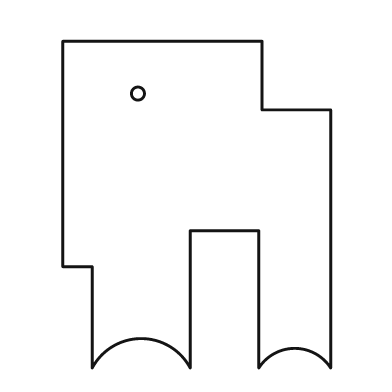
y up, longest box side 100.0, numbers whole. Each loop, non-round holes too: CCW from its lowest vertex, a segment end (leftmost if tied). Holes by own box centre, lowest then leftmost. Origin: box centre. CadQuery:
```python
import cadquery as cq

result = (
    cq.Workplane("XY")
    .moveTo(-32.0, -50.0)
    .threePointArc((-17.0, -41.0), (-2.0, -50.0))
    .lineTo(-2.0, -8.0)
    .lineTo(19.0, -8.0)
    .lineTo(19.0, -50.0)
    .threePointArc((30.0, -44.0), (41.0, -50.0))
    .lineTo(41.0, 29.0)
    .lineTo(20.0, 29.0)
    .lineTo(20.0, 50.0)
    .lineTo(-41.0, 50.0)
    .lineTo(-41.0, -19.0)
    .lineTo(-32.0, -19.0)
    .close()
    .moveTo(-18.0, 34.0)
    .circle(2.0)
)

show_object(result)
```